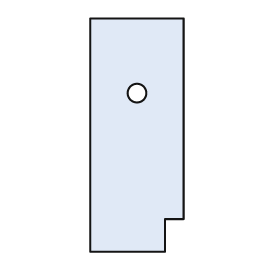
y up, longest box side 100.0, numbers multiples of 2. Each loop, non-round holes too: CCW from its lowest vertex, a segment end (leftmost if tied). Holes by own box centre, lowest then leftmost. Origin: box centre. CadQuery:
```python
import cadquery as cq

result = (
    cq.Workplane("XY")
    .moveTo(-20.0, -50.0)
    .lineTo(12.0, -50.0)
    .lineTo(12.0, -36.0)
    .lineTo(20.0, -36.0)
    .lineTo(20.0, 50.0)
    .lineTo(-20.0, 50.0)
    .close()
    .moveTo(0.0, 18.0)
    .circle(4.0)
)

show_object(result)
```